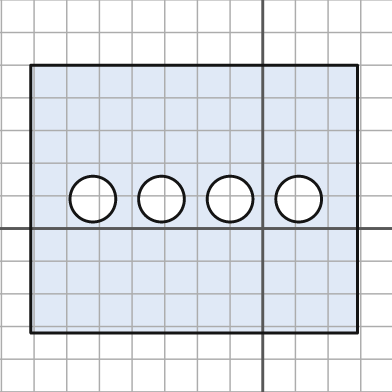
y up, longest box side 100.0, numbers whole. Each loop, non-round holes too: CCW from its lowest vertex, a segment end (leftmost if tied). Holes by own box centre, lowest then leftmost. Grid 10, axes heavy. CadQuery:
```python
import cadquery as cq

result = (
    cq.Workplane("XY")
    .moveTo(-71.0, -32.0)
    .lineTo(29.0, -32.0)
    .lineTo(29.0, 50.0)
    .lineTo(-71.0, 50.0)
    .close()
    .moveTo(-52.0, 9.0)
    .circle(7.0)
    .moveTo(-31.0, 9.0)
    .circle(7.0)
    .moveTo(-10.0, 9.0)
    .circle(7.0)
    .moveTo(11.0, 9.0)
    .circle(7.0)
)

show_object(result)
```